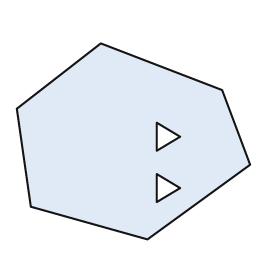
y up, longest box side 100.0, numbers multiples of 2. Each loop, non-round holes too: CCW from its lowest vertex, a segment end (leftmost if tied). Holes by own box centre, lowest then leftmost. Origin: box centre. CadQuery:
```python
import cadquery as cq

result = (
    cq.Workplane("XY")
    .moveTo(6.0, -42.0)
    .lineTo(50.0, -10.0)
    .lineTo(38.0, 22.0)
    .lineTo(-14.0, 42.0)
    .lineTo(-50.0, 14.0)
    .lineTo(-44.0, -28.0)
    .close()
    .moveTo(10.0, -26.0)
    .lineTo(20.0, -20.0)
    .lineTo(10.0, -14.0)
    .close()
    .moveTo(10.0, -4.0)
    .lineTo(20.0, 2.0)
    .lineTo(10.0, 8.0)
    .close()
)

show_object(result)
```